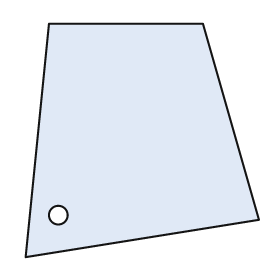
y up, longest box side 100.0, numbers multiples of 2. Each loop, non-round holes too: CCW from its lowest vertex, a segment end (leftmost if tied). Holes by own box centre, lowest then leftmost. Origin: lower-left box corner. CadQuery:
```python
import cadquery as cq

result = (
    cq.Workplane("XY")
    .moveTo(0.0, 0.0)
    .lineTo(100.0, 16.0)
    .lineTo(76.0, 100.0)
    .lineTo(10.0, 100.0)
    .close()
    .moveTo(14.0, 18.0)
    .circle(4.0)
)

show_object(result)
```